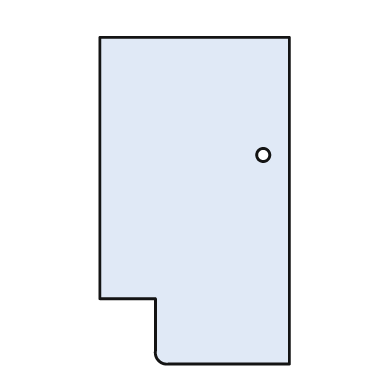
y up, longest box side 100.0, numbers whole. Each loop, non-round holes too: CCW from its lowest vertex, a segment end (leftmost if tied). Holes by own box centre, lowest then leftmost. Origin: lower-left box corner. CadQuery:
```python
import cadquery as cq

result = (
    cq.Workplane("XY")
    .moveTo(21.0, 0.0)
    .lineTo(58.0, 0.0)
    .lineTo(58.0, 100.0)
    .lineTo(0.0, 100.0)
    .lineTo(0.0, 20.0)
    .lineTo(17.0, 20.0)
    .lineTo(17.0, 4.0)
    .threePointArc((18.0, 1.0), (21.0, 0.0))
    .close()
    .moveTo(50.0, 64.0)
    .circle(2.0)
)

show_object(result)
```